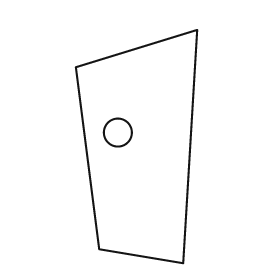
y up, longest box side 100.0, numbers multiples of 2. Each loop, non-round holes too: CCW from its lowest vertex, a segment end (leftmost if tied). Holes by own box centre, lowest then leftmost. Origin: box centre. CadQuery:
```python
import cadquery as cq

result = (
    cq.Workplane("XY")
    .moveTo(20.0, -50.0)
    .lineTo(26.0, 50.0)
    .lineTo(-26.0, 34.0)
    .lineTo(-16.0, -44.0)
    .close()
    .moveTo(-8.0, 6.0)
    .circle(6.0)
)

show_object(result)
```